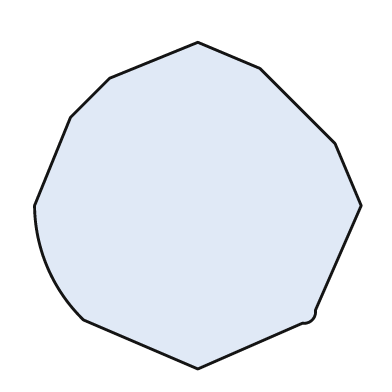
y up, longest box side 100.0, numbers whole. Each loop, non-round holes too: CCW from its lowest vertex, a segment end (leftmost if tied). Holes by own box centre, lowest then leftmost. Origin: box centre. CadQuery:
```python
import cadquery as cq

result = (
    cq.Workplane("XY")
    .moveTo(0.0, -50.0)
    .lineTo(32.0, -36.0)
    .threePointArc((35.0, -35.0), (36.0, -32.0))
    .lineTo(50.0, 0.0)
    .lineTo(42.0, 19.0)
    .lineTo(19.0, 42.0)
    .lineTo(0.0, 50.0)
    .lineTo(-27.0, 39.0)
    .lineTo(-39.0, 27.0)
    .lineTo(-50.0, 0.0)
    .threePointArc((-46.0, -19.0), (-35.0, -35.0))
    .close()
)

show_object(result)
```